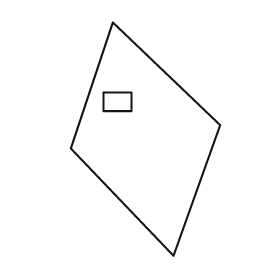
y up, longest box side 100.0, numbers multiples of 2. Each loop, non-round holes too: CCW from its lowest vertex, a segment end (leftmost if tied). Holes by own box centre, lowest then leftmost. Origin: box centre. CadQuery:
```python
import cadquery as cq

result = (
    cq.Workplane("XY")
    .moveTo(12.0, -50.0)
    .lineTo(32.0, 6.0)
    .lineTo(-14.0, 50.0)
    .lineTo(-32.0, -4.0)
    .close()
    .moveTo(-18.0, 12.0)
    .lineTo(-6.0, 12.0)
    .lineTo(-6.0, 20.0)
    .lineTo(-18.0, 20.0)
    .close()
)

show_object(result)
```